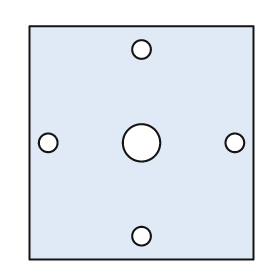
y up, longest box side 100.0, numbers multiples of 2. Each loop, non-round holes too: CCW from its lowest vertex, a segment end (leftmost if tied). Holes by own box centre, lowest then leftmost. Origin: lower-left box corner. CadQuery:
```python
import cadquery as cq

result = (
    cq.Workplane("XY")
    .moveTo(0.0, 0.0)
    .lineTo(96.0, 0.0)
    .lineTo(96.0, 100.0)
    .lineTo(0.0, 100.0)
    .close()
    .moveTo(48.0, 10.0)
    .circle(4.0)
    .moveTo(8.0, 50.0)
    .circle(4.0)
    .moveTo(48.0, 50.0)
    .circle(8.0)
    .moveTo(88.0, 50.0)
    .circle(4.0)
    .moveTo(48.0, 90.0)
    .circle(4.0)
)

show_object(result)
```